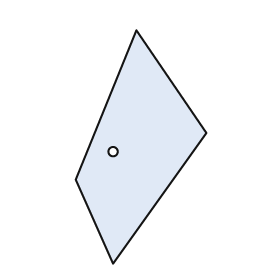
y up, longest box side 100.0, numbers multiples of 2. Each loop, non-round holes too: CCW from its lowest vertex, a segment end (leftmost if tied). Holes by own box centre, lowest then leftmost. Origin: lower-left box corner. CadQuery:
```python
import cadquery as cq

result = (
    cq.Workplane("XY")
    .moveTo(16.0, 0.0)
    .lineTo(56.0, 56.0)
    .lineTo(26.0, 100.0)
    .lineTo(0.0, 36.0)
    .close()
    .moveTo(16.0, 48.0)
    .circle(2.0)
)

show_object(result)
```